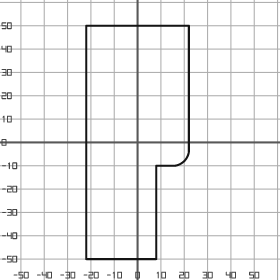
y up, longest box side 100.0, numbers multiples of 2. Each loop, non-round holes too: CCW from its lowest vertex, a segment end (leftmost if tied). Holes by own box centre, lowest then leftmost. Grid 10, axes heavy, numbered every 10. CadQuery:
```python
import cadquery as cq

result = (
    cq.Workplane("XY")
    .moveTo(-22.0, -50.0)
    .lineTo(8.0, -50.0)
    .lineTo(8.0, -10.0)
    .lineTo(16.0, -10.0)
    .threePointArc((20.0, -8.0), (22.0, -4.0))
    .lineTo(22.0, 50.0)
    .lineTo(-22.0, 50.0)
    .close()
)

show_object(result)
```